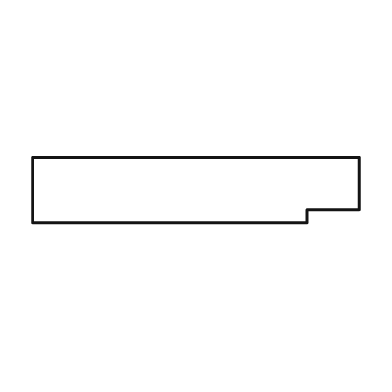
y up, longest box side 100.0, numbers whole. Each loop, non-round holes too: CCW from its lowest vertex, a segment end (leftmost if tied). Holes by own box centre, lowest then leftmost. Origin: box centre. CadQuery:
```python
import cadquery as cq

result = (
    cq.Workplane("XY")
    .moveTo(-50.0, -10.0)
    .lineTo(34.0, -10.0)
    .lineTo(34.0, -6.0)
    .lineTo(50.0, -6.0)
    .lineTo(50.0, 10.0)
    .lineTo(-50.0, 10.0)
    .close()
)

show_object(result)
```